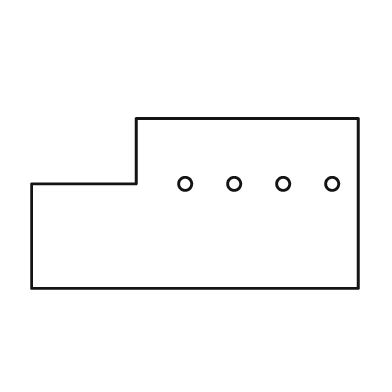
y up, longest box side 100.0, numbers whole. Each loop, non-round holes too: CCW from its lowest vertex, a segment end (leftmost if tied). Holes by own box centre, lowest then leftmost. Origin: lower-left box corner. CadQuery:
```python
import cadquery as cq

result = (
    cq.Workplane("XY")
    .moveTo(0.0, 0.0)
    .lineTo(100.0, 0.0)
    .lineTo(100.0, 52.0)
    .lineTo(32.0, 52.0)
    .lineTo(32.0, 32.0)
    .lineTo(0.0, 32.0)
    .close()
    .moveTo(47.0, 32.0)
    .circle(2.0)
    .moveTo(62.0, 32.0)
    .circle(2.0)
    .moveTo(77.0, 32.0)
    .circle(2.0)
    .moveTo(92.0, 32.0)
    .circle(2.0)
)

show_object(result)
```